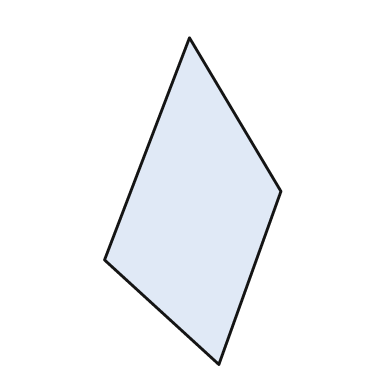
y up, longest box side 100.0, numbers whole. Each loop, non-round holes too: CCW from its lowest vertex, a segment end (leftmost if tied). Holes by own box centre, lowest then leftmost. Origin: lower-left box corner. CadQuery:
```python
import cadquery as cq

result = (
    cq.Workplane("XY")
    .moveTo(35.0, 0.0)
    .lineTo(54.0, 53.0)
    .lineTo(26.0, 100.0)
    .lineTo(0.0, 32.0)
    .close()
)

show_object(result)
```